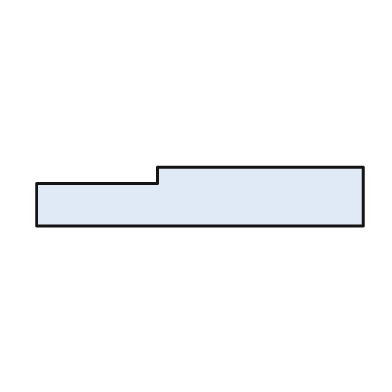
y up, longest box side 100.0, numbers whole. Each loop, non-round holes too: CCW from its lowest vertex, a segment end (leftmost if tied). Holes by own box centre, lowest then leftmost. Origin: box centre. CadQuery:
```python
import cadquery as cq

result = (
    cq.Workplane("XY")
    .moveTo(-50.0, -9.0)
    .lineTo(50.0, -9.0)
    .lineTo(50.0, 9.0)
    .lineTo(-13.0, 9.0)
    .lineTo(-13.0, 4.0)
    .lineTo(-50.0, 4.0)
    .close()
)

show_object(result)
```